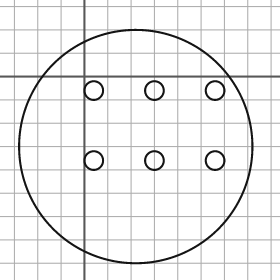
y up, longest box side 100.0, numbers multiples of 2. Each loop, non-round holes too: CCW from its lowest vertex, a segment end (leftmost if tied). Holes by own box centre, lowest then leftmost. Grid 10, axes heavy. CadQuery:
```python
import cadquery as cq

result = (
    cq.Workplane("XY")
    .moveTo(22.0, -30.0)
    .circle(50.0)
    .moveTo(4.0, -36.0)
    .circle(4.0)
    .moveTo(30.0, -36.0)
    .circle(4.0)
    .moveTo(56.0, -36.0)
    .circle(4.0)
    .moveTo(4.0, -6.0)
    .circle(4.0)
    .moveTo(30.0, -6.0)
    .circle(4.0)
    .moveTo(56.0, -6.0)
    .circle(4.0)
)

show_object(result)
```